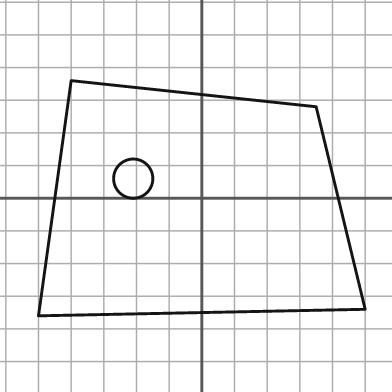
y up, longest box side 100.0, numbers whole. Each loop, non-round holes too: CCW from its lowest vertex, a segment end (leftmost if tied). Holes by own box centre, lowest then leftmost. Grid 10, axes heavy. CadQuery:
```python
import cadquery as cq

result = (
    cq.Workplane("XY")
    .moveTo(-50.0, -36.0)
    .lineTo(50.0, -34.0)
    .lineTo(35.0, 28.0)
    .lineTo(-40.0, 36.0)
    .close()
    .moveTo(-21.0, 6.0)
    .circle(6.0)
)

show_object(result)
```